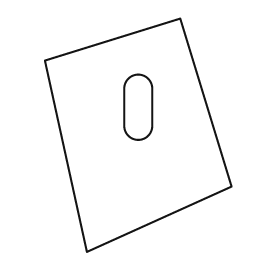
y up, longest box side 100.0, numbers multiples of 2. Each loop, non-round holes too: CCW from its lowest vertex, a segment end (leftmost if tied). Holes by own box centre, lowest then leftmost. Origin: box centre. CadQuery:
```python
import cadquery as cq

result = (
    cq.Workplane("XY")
    .moveTo(-22.0, -50.0)
    .lineTo(40.0, -22.0)
    .lineTo(18.0, 50.0)
    .lineTo(-40.0, 32.0)
    .close()
    .moveTo(-6.0, 4.0)
    .threePointArc((0.0, -2.0), (6.0, 4.0))
    .lineTo(6.0, 20.0)
    .threePointArc((0.0, 26.0), (-6.0, 20.0))
    .close()
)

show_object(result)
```